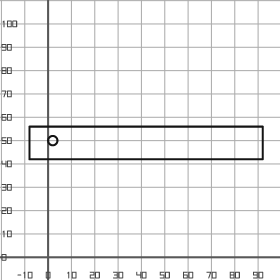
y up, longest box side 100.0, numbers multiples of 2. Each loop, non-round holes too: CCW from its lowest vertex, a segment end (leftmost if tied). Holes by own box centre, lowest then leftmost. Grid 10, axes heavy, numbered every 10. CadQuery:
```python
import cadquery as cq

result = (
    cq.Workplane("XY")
    .moveTo(-8.0, 42.0)
    .lineTo(92.0, 42.0)
    .lineTo(92.0, 56.0)
    .lineTo(-8.0, 56.0)
    .close()
    .moveTo(2.0, 50.0)
    .circle(2.0)
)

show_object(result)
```